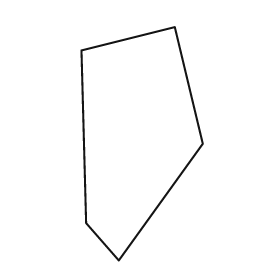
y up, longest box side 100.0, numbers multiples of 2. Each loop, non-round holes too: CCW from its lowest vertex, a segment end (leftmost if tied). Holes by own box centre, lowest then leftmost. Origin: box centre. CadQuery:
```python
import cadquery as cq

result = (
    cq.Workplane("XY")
    .moveTo(-10.0, -50.0)
    .lineTo(26.0, 0.0)
    .lineTo(14.0, 50.0)
    .lineTo(-26.0, 40.0)
    .lineTo(-24.0, -34.0)
    .close()
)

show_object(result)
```